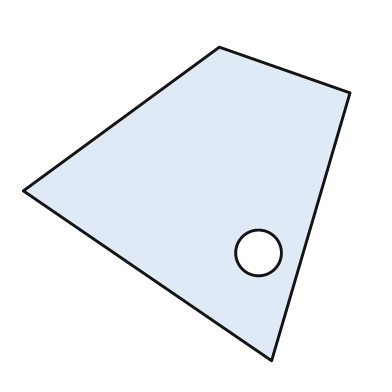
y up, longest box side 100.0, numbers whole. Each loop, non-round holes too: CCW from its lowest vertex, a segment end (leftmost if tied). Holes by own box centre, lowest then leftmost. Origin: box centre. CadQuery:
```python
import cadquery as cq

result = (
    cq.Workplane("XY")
    .moveTo(26.0, -48.0)
    .lineTo(50.0, 34.0)
    .lineTo(10.0, 48.0)
    .lineTo(-50.0, 4.0)
    .close()
    .moveTo(22.0, -15.0)
    .circle(7.0)
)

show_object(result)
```